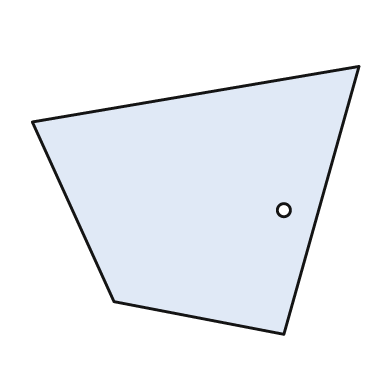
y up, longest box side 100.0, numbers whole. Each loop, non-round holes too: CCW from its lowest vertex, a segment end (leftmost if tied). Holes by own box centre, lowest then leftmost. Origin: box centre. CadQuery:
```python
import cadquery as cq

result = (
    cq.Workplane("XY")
    .moveTo(27.0, -41.0)
    .lineTo(50.0, 41.0)
    .lineTo(-50.0, 24.0)
    .lineTo(-25.0, -31.0)
    .close()
    .moveTo(27.0, -3.0)
    .circle(2.0)
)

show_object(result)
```